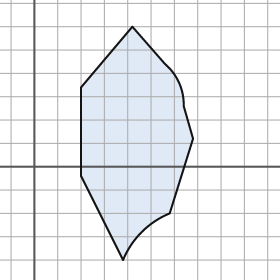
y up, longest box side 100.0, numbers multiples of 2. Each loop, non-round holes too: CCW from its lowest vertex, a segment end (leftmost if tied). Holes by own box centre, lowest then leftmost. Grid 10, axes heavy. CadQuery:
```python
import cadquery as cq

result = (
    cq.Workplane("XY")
    .moveTo(38.0, -40.0)
    .threePointArc((46.0, -28.0), (58.0, -20.0))
    .lineTo(68.0, 12.0)
    .lineTo(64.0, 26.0)
    .threePointArc((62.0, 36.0), (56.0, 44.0))
    .lineTo(42.0, 60.0)
    .lineTo(20.0, 34.0)
    .lineTo(20.0, -4.0)
    .close()
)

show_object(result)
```